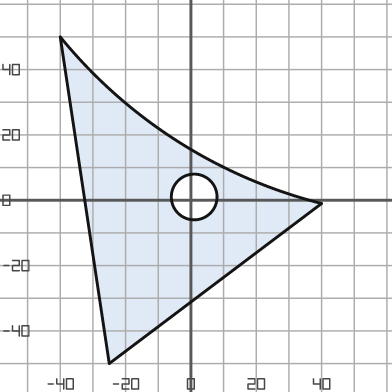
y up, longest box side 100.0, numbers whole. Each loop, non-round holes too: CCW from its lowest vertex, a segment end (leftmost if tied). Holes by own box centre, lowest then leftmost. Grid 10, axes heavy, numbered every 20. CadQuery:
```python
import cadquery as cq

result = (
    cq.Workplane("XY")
    .moveTo(-25.0, -50.0)
    .lineTo(40.0, -1.0)
    .threePointArc((-4.0, 18.0), (-40.0, 50.0))
    .close()
    .moveTo(1.0, 1.0)
    .circle(7.0)
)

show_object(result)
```